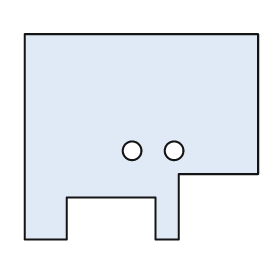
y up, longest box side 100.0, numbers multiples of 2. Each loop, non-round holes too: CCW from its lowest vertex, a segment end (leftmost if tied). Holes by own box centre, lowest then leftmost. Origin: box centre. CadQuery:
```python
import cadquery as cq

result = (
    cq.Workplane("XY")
    .moveTo(-50.0, -44.0)
    .lineTo(-32.0, -44.0)
    .lineTo(-32.0, -26.0)
    .lineTo(6.0, -26.0)
    .lineTo(6.0, -44.0)
    .lineTo(16.0, -44.0)
    .lineTo(16.0, -16.0)
    .lineTo(50.0, -16.0)
    .lineTo(50.0, 44.0)
    .lineTo(-50.0, 44.0)
    .close()
    .moveTo(-4.0, -6.0)
    .circle(4.0)
    .moveTo(14.0, -6.0)
    .circle(4.0)
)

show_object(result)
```